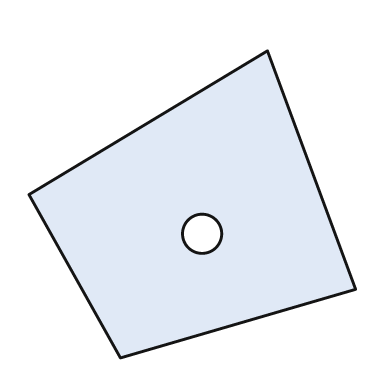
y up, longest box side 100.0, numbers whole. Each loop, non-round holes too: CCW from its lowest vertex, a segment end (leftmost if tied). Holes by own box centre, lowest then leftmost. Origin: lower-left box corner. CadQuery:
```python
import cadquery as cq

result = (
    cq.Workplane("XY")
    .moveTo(28.0, 0.0)
    .lineTo(100.0, 21.0)
    .lineTo(73.0, 94.0)
    .lineTo(0.0, 50.0)
    .close()
    .moveTo(53.0, 38.0)
    .circle(6.0)
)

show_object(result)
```